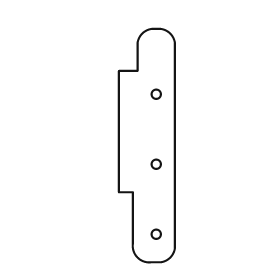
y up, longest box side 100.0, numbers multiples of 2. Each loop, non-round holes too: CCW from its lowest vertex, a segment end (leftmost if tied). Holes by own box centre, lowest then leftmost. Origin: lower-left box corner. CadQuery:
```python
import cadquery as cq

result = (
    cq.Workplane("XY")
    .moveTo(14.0, 0.0)
    .lineTo(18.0, 0.0)
    .threePointArc((22.0, 2.0), (24.0, 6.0))
    .lineTo(24.0, 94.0)
    .threePointArc((22.0, 98.0), (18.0, 100.0))
    .lineTo(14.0, 100.0)
    .threePointArc((10.0, 98.0), (8.0, 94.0))
    .lineTo(8.0, 82.0)
    .lineTo(0.0, 82.0)
    .lineTo(0.0, 30.0)
    .lineTo(6.0, 30.0)
    .lineTo(6.0, 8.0)
    .threePointArc((8.0, 2.0), (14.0, 0.0))
    .close()
    .moveTo(16.0, 12.0)
    .circle(2.0)
    .moveTo(16.0, 42.0)
    .circle(2.0)
    .moveTo(16.0, 72.0)
    .circle(2.0)
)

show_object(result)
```